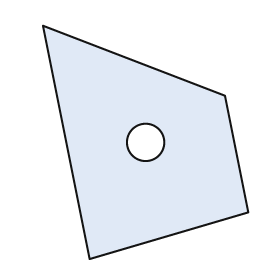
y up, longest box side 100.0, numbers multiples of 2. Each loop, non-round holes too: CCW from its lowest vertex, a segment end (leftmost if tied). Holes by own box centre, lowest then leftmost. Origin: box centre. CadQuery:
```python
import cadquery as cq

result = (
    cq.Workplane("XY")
    .moveTo(-24.0, -50.0)
    .lineTo(44.0, -30.0)
    .lineTo(34.0, 20.0)
    .lineTo(-44.0, 50.0)
    .close()
    .moveTo(0.0, 0.0)
    .circle(8.0)
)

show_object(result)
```